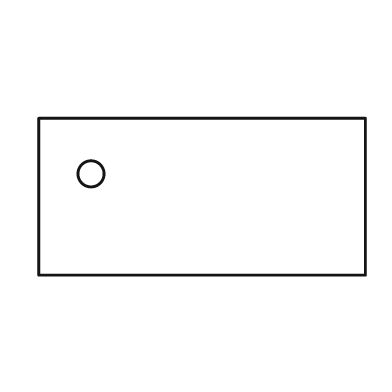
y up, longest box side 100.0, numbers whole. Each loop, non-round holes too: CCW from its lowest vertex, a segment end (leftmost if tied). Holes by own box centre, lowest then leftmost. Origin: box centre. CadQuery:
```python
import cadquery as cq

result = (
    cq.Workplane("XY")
    .moveTo(-50.0, -24.0)
    .lineTo(50.0, -24.0)
    .lineTo(50.0, 24.0)
    .lineTo(-50.0, 24.0)
    .close()
    .moveTo(-34.0, 7.0)
    .circle(4.0)
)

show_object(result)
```